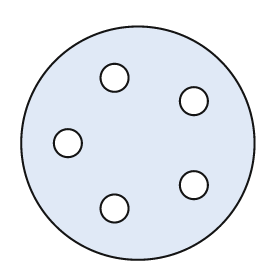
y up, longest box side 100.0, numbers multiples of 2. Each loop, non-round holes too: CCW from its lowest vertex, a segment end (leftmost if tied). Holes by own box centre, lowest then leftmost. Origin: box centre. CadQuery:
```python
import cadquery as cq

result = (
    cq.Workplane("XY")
    .moveTo(0.0, 0.0)
    .circle(50.0)
    .moveTo(-10.0, -28.0)
    .circle(6.0)
    .moveTo(24.0, -18.0)
    .circle(6.0)
    .moveTo(-30.0, 0.0)
    .circle(6.0)
    .moveTo(24.0, 18.0)
    .circle(6.0)
    .moveTo(-10.0, 28.0)
    .circle(6.0)
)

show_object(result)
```